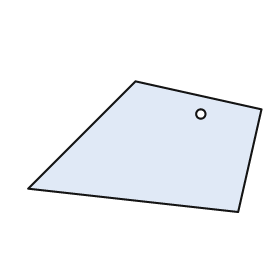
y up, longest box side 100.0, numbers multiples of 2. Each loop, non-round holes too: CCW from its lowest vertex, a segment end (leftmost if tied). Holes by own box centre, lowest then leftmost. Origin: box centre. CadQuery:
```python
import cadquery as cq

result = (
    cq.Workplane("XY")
    .moveTo(40.0, -28.0)
    .lineTo(50.0, 16.0)
    .lineTo(-4.0, 28.0)
    .lineTo(-50.0, -18.0)
    .close()
    .moveTo(24.0, 14.0)
    .circle(2.0)
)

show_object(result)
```